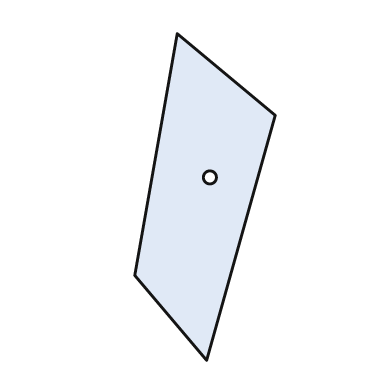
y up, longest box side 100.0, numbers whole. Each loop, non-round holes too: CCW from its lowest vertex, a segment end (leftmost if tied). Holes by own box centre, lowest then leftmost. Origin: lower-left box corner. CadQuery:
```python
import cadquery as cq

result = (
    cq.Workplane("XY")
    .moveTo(22.0, 0.0)
    .lineTo(43.0, 75.0)
    .lineTo(13.0, 100.0)
    .lineTo(0.0, 26.0)
    .close()
    .moveTo(23.0, 56.0)
    .circle(2.0)
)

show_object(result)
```